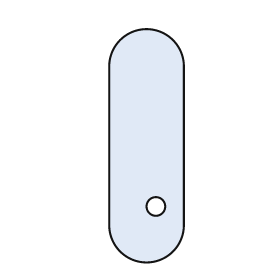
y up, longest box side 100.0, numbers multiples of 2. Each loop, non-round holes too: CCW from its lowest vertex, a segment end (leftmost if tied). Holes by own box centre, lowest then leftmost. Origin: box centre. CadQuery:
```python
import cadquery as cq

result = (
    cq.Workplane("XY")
    .moveTo(-16.0, -34.0)
    .threePointArc((0.0, -50.0), (16.0, -34.0))
    .lineTo(16.0, 34.0)
    .threePointArc((0.0, 50.0), (-16.0, 34.0))
    .close()
    .moveTo(4.0, -26.0)
    .circle(4.0)
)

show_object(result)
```